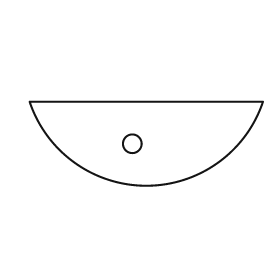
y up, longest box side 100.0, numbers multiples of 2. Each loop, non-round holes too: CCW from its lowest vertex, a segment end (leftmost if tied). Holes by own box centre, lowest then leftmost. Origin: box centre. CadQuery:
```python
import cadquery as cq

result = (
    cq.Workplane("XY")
    .moveTo(-50.0, 18.0)
    .threePointArc((0.0, -18.0), (50.0, 18.0))
    .close()
    .moveTo(-6.0, 0.0)
    .circle(4.0)
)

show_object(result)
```